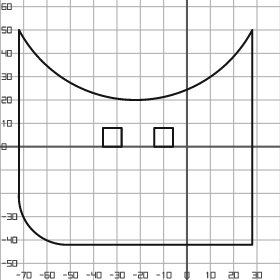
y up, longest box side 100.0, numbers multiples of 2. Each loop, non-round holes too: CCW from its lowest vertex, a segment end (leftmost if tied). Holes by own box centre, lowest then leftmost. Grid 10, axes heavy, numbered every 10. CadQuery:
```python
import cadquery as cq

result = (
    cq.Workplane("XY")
    .moveTo(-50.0, -42.0)
    .lineTo(28.0, -42.0)
    .lineTo(28.0, 50.0)
    .threePointArc((-22.0, 20.0), (-72.0, 50.0))
    .lineTo(-72.0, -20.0)
    .threePointArc((-66.0, -36.0), (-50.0, -42.0))
    .close()
    .moveTo(-36.0, 0.0)
    .lineTo(-28.0, 0.0)
    .lineTo(-28.0, 8.0)
    .lineTo(-36.0, 8.0)
    .close()
    .moveTo(-14.0, 0.0)
    .lineTo(-6.0, 0.0)
    .lineTo(-6.0, 8.0)
    .lineTo(-14.0, 8.0)
    .close()
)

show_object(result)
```